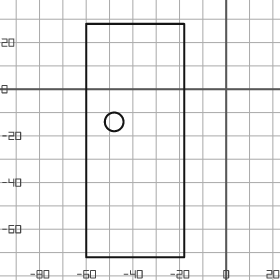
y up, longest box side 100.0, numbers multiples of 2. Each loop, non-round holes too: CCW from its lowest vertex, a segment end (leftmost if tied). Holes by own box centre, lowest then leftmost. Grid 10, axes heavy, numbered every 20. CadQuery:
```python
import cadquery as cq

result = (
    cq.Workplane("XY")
    .moveTo(-60.0, -72.0)
    .lineTo(-18.0, -72.0)
    .lineTo(-18.0, 28.0)
    .lineTo(-60.0, 28.0)
    .close()
    .moveTo(-48.0, -14.0)
    .circle(4.0)
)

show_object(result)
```